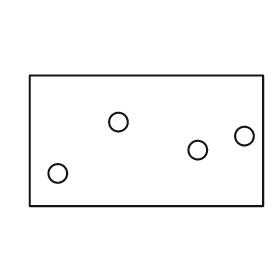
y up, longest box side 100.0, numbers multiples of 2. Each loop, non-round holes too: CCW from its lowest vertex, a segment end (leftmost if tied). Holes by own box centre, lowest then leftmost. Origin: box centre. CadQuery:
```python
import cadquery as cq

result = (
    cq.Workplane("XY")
    .moveTo(-50.0, -28.0)
    .lineTo(50.0, -28.0)
    .lineTo(50.0, 28.0)
    .lineTo(-50.0, 28.0)
    .close()
    .moveTo(-38.0, -14.0)
    .circle(4.0)
    .moveTo(22.0, -4.0)
    .circle(4.0)
    .moveTo(42.0, 2.0)
    .circle(4.0)
    .moveTo(-12.0, 8.0)
    .circle(4.0)
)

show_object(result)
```